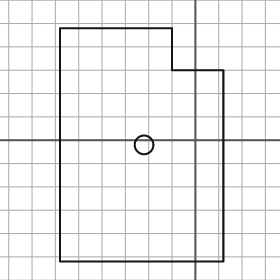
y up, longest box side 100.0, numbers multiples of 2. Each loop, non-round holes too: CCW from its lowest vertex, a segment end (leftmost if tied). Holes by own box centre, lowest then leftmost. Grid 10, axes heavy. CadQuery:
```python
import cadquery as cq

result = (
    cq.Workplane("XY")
    .moveTo(-58.0, -52.0)
    .lineTo(12.0, -52.0)
    .lineTo(12.0, 30.0)
    .lineTo(-10.0, 30.0)
    .lineTo(-10.0, 48.0)
    .lineTo(-58.0, 48.0)
    .close()
    .moveTo(-22.0, -2.0)
    .circle(4.0)
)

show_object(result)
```